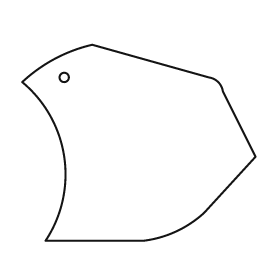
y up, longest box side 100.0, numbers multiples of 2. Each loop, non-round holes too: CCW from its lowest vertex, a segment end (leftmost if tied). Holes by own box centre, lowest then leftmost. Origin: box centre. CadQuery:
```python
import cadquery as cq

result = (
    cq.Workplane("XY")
    .moveTo(-40.0, -42.0)
    .lineTo(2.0, -42.0)
    .threePointArc((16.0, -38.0), (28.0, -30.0))
    .lineTo(50.0, -6.0)
    .lineTo(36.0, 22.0)
    .threePointArc((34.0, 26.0), (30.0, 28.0))
    .lineTo(-20.0, 42.0)
    .threePointArc((-36.0, 36.0), (-50.0, 26.0))
    .threePointArc((-32.0, -6.0), (-40.0, -42.0))
    .close()
    .moveTo(-32.0, 28.0)
    .circle(2.0)
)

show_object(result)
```